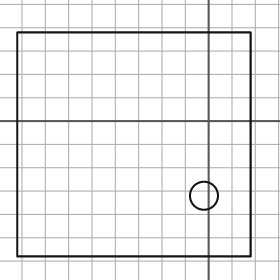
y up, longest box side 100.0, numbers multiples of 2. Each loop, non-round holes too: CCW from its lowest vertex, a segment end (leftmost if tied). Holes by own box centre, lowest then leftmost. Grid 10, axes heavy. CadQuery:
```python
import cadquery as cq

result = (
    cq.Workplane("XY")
    .moveTo(-82.0, -58.0)
    .lineTo(18.0, -58.0)
    .lineTo(18.0, 38.0)
    .lineTo(-82.0, 38.0)
    .close()
    .moveTo(-2.0, -32.0)
    .circle(6.0)
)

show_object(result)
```